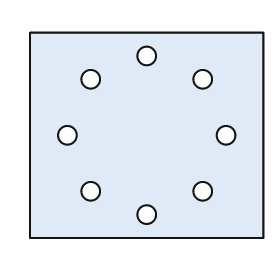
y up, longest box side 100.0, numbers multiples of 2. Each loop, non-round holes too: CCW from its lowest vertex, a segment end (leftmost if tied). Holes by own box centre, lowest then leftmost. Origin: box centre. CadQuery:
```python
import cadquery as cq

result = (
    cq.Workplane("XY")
    .moveTo(-50.0, -44.0)
    .lineTo(50.0, -44.0)
    .lineTo(50.0, 44.0)
    .lineTo(-50.0, 44.0)
    .close()
    .moveTo(0.0, -34.0)
    .circle(4.0)
    .moveTo(-24.0, -24.0)
    .circle(4.0)
    .moveTo(24.0, -24.0)
    .circle(4.0)
    .moveTo(-34.0, 0.0)
    .circle(4.0)
    .moveTo(34.0, 0.0)
    .circle(4.0)
    .moveTo(-24.0, 24.0)
    .circle(4.0)
    .moveTo(24.0, 24.0)
    .circle(4.0)
    .moveTo(0.0, 34.0)
    .circle(4.0)
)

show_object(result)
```